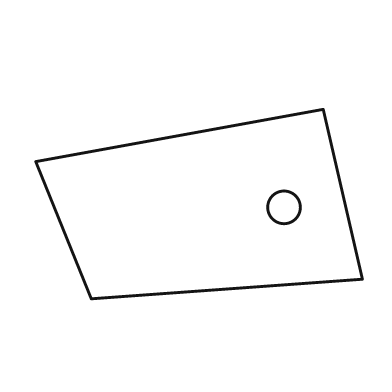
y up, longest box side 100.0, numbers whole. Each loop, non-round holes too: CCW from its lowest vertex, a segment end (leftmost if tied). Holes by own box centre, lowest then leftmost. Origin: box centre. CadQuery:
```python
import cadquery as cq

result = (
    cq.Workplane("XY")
    .moveTo(-33.0, -29.0)
    .lineTo(50.0, -23.0)
    .lineTo(38.0, 29.0)
    .lineTo(-50.0, 13.0)
    .close()
    .moveTo(26.0, -1.0)
    .circle(5.0)
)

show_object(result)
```